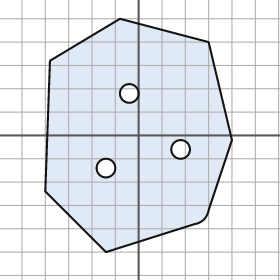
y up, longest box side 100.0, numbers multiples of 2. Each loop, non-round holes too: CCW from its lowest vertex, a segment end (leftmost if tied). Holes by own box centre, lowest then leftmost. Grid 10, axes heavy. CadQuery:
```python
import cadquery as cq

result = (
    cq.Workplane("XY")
    .moveTo(-14.0, -50.0)
    .lineTo(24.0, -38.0)
    .threePointArc((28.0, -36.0), (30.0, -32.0))
    .lineTo(40.0, -2.0)
    .lineTo(30.0, 40.0)
    .lineTo(-8.0, 50.0)
    .lineTo(-38.0, 32.0)
    .lineTo(-40.0, -24.0)
    .close()
    .moveTo(-14.0, -14.0)
    .circle(4.0)
    .moveTo(18.0, -6.0)
    .circle(4.0)
    .moveTo(-4.0, 18.0)
    .circle(4.0)
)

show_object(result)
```